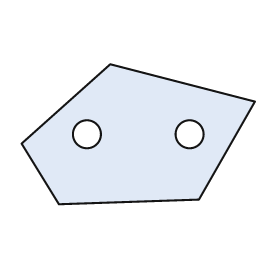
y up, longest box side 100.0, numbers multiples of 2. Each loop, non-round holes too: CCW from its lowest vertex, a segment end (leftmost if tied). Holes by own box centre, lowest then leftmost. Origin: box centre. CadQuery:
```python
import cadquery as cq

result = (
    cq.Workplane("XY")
    .moveTo(-34.0, -30.0)
    .lineTo(26.0, -28.0)
    .lineTo(50.0, 14.0)
    .lineTo(-12.0, 30.0)
    .lineTo(-50.0, -4.0)
    .close()
    .moveTo(-22.0, 0.0)
    .circle(6.0)
    .moveTo(22.0, 0.0)
    .circle(6.0)
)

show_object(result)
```